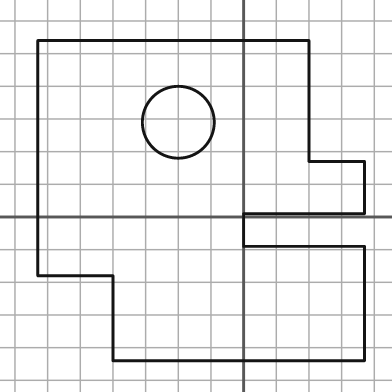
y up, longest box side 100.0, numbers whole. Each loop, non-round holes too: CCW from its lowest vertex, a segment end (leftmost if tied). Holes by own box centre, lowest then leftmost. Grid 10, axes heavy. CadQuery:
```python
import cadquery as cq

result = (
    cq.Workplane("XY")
    .moveTo(-40.0, -44.0)
    .lineTo(37.0, -44.0)
    .lineTo(37.0, -9.0)
    .lineTo(0.0, -9.0)
    .lineTo(0.0, 1.0)
    .lineTo(37.0, 1.0)
    .lineTo(37.0, 17.0)
    .lineTo(20.0, 17.0)
    .lineTo(20.0, 54.0)
    .lineTo(-63.0, 54.0)
    .lineTo(-63.0, -18.0)
    .lineTo(-40.0, -18.0)
    .close()
    .moveTo(-20.0, 29.0)
    .circle(11.0)
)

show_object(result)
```